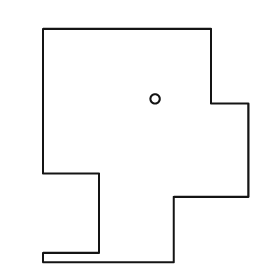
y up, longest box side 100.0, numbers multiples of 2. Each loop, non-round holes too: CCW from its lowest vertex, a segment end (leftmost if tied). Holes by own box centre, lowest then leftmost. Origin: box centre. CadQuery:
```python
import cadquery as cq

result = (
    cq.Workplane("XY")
    .moveTo(-44.0, -50.0)
    .lineTo(12.0, -50.0)
    .lineTo(12.0, -22.0)
    .lineTo(44.0, -22.0)
    .lineTo(44.0, 18.0)
    .lineTo(28.0, 18.0)
    .lineTo(28.0, 50.0)
    .lineTo(-44.0, 50.0)
    .lineTo(-44.0, -12.0)
    .lineTo(-20.0, -12.0)
    .lineTo(-20.0, -46.0)
    .lineTo(-44.0, -46.0)
    .close()
    .moveTo(4.0, 20.0)
    .circle(2.0)
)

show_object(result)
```